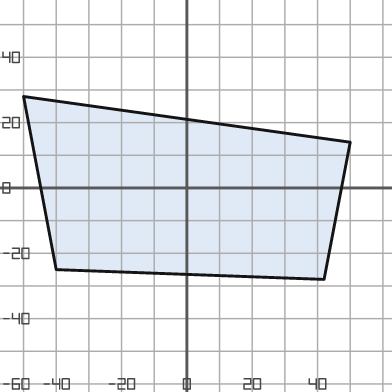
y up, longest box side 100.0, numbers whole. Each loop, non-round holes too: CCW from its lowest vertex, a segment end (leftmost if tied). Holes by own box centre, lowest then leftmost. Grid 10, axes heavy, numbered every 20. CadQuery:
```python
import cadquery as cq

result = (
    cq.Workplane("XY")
    .moveTo(42.0, -28.0)
    .lineTo(50.0, 14.0)
    .lineTo(-50.0, 28.0)
    .lineTo(-40.0, -25.0)
    .close()
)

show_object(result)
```